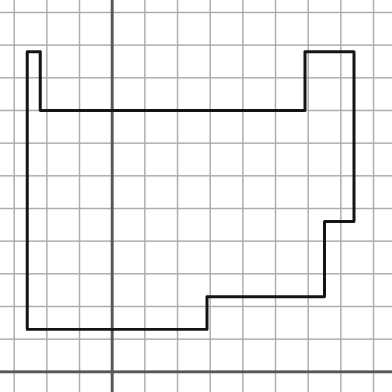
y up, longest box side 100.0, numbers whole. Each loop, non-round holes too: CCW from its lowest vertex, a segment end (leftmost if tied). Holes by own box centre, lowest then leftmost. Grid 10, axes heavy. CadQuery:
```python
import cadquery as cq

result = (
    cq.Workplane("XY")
    .moveTo(-26.0, 13.0)
    .lineTo(29.0, 13.0)
    .lineTo(29.0, 23.0)
    .lineTo(65.0, 23.0)
    .lineTo(65.0, 46.0)
    .lineTo(74.0, 46.0)
    .lineTo(74.0, 98.0)
    .lineTo(59.0, 98.0)
    .lineTo(59.0, 80.0)
    .lineTo(-22.0, 80.0)
    .lineTo(-22.0, 98.0)
    .lineTo(-26.0, 98.0)
    .close()
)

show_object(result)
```